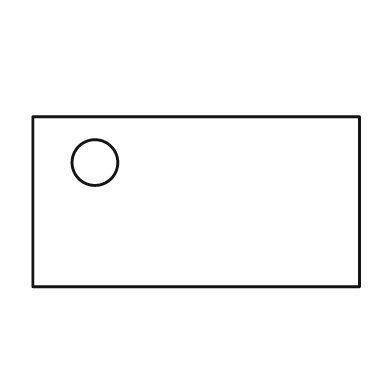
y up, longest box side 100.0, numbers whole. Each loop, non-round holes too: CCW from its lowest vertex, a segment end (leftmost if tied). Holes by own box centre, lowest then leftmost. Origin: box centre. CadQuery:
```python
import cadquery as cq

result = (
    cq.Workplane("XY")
    .moveTo(-50.0, -26.0)
    .lineTo(50.0, -26.0)
    .lineTo(50.0, 26.0)
    .lineTo(-50.0, 26.0)
    .close()
    .moveTo(-31.0, 12.0)
    .circle(7.0)
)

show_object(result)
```